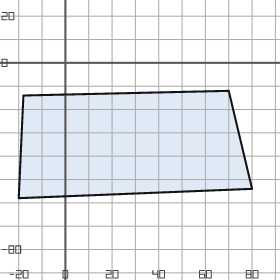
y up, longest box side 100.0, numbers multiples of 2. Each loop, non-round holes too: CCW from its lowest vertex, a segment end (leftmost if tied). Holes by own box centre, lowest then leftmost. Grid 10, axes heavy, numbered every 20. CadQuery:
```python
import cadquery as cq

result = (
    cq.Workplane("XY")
    .moveTo(-20.0, -58.0)
    .lineTo(80.0, -54.0)
    .lineTo(70.0, -12.0)
    .lineTo(-18.0, -14.0)
    .close()
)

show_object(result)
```